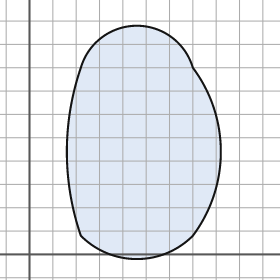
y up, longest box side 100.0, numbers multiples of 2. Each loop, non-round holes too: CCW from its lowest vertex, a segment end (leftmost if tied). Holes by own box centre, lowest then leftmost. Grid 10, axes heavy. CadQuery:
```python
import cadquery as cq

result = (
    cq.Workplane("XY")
    .moveTo(22.0, 8.0)
    .threePointArc((46.0, -2.0), (70.0, 8.0))
    .threePointArc((82.0, 44.0), (70.0, 80.0))
    .threePointArc((46.0, 98.0), (22.0, 80.0))
    .threePointArc((16.0, 44.0), (22.0, 8.0))
    .close()
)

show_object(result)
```